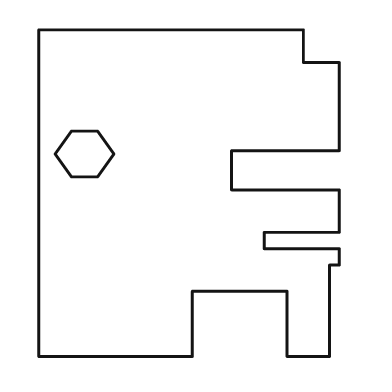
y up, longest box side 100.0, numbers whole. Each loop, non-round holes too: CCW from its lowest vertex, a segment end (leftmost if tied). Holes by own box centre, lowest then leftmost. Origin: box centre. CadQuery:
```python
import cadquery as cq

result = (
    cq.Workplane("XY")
    .moveTo(-46.0, -50.0)
    .lineTo(1.0, -50.0)
    .lineTo(1.0, -30.0)
    .lineTo(30.0, -30.0)
    .lineTo(30.0, -50.0)
    .lineTo(43.0, -50.0)
    .lineTo(43.0, -22.0)
    .lineTo(46.0, -22.0)
    .lineTo(46.0, -17.0)
    .lineTo(23.0, -17.0)
    .lineTo(23.0, -12.0)
    .lineTo(46.0, -12.0)
    .lineTo(46.0, 1.0)
    .lineTo(13.0, 1.0)
    .lineTo(13.0, 13.0)
    .lineTo(46.0, 13.0)
    .lineTo(46.0, 40.0)
    .lineTo(35.0, 40.0)
    .lineTo(35.0, 50.0)
    .lineTo(-46.0, 50.0)
    .close()
    .moveTo(-36.0, 5.0)
    .lineTo(-28.0, 5.0)
    .lineTo(-23.0, 12.0)
    .lineTo(-28.0, 19.0)
    .lineTo(-36.0, 19.0)
    .lineTo(-41.0, 12.0)
    .close()
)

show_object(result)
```